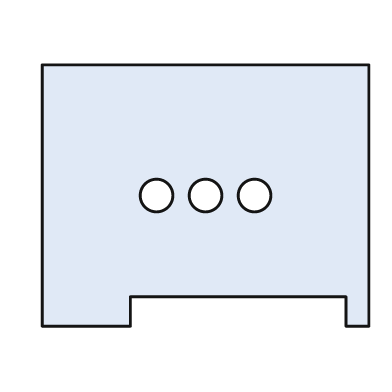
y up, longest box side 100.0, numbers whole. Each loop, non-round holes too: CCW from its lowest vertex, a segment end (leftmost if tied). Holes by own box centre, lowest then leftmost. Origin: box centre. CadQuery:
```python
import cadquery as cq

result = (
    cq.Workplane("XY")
    .moveTo(-50.0, -40.0)
    .lineTo(-23.0, -40.0)
    .lineTo(-23.0, -31.0)
    .lineTo(43.0, -31.0)
    .lineTo(43.0, -40.0)
    .lineTo(50.0, -40.0)
    .lineTo(50.0, 40.0)
    .lineTo(-50.0, 40.0)
    .close()
    .moveTo(-15.0, 0.0)
    .circle(5.0)
    .moveTo(0.0, 0.0)
    .circle(5.0)
    .moveTo(15.0, 0.0)
    .circle(5.0)
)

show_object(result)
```